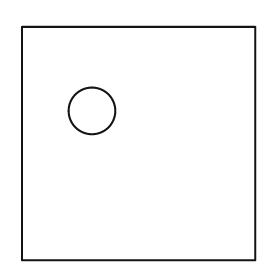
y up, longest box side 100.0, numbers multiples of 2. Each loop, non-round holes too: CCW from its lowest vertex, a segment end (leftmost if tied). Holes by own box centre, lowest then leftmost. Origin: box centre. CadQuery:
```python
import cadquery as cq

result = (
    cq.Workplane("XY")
    .moveTo(-50.0, -50.0)
    .lineTo(50.0, -50.0)
    .lineTo(50.0, 50.0)
    .lineTo(-50.0, 50.0)
    .close()
    .moveTo(-20.0, 14.0)
    .circle(10.0)
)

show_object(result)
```